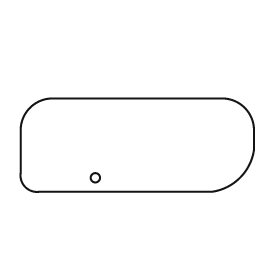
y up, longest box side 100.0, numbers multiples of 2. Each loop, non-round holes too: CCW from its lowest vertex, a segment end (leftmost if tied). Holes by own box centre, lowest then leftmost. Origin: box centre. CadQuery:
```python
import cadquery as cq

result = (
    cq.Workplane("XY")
    .moveTo(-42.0, -20.0)
    .lineTo(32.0, -20.0)
    .threePointArc((44.0, -14.0), (50.0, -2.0))
    .lineTo(50.0, 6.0)
    .threePointArc((46.0, 16.0), (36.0, 20.0))
    .lineTo(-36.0, 20.0)
    .threePointArc((-46.0, 16.0), (-50.0, 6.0))
    .lineTo(-50.0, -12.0)
    .threePointArc((-48.0, -18.0), (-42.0, -20.0))
    .close()
    .moveTo(-18.0, -14.0)
    .circle(2.0)
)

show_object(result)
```